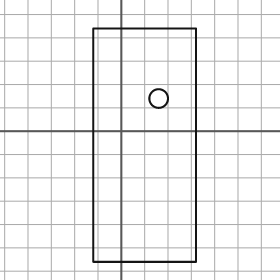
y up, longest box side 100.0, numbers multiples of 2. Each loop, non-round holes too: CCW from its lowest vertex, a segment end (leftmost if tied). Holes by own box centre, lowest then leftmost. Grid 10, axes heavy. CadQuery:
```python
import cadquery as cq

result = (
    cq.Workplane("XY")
    .moveTo(-12.0, -56.0)
    .lineTo(32.0, -56.0)
    .lineTo(32.0, 44.0)
    .lineTo(-12.0, 44.0)
    .close()
    .moveTo(16.0, 14.0)
    .circle(4.0)
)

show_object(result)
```